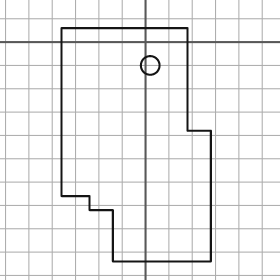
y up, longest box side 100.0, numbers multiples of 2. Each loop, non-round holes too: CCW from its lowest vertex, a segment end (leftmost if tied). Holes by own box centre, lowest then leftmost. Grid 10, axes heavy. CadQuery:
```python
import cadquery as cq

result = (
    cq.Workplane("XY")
    .moveTo(-14.0, -94.0)
    .lineTo(28.0, -94.0)
    .lineTo(28.0, -38.0)
    .lineTo(18.0, -38.0)
    .lineTo(18.0, 6.0)
    .lineTo(-36.0, 6.0)
    .lineTo(-36.0, -66.0)
    .lineTo(-24.0, -66.0)
    .lineTo(-24.0, -72.0)
    .lineTo(-14.0, -72.0)
    .close()
    .moveTo(2.0, -10.0)
    .circle(4.0)
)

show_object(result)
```